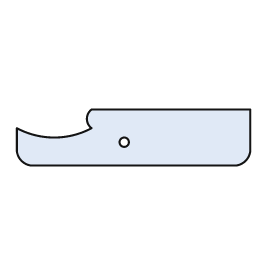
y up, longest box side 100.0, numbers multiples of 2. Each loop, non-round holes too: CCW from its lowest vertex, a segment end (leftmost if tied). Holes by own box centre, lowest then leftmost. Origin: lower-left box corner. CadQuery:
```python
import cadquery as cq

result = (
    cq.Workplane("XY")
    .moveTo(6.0, 0.0)
    .lineTo(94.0, 0.0)
    .threePointArc((98.0, 2.0), (100.0, 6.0))
    .lineTo(100.0, 24.0)
    .lineTo(32.0, 24.0)
    .threePointArc((30.0, 20.0), (32.0, 16.0))
    .threePointArc((16.0, 12.0), (0.0, 16.0))
    .lineTo(0.0, 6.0)
    .threePointArc((2.0, 2.0), (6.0, 0.0))
    .close()
    .moveTo(46.0, 10.0)
    .circle(2.0)
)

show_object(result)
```